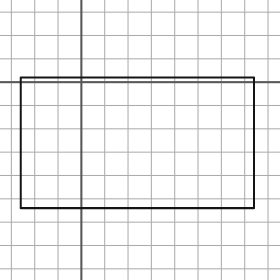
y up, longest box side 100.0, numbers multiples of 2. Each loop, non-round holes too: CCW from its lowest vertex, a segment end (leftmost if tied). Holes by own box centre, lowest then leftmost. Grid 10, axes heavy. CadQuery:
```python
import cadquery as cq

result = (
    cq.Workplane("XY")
    .moveTo(-26.0, -54.0)
    .lineTo(74.0, -54.0)
    .lineTo(74.0, 2.0)
    .lineTo(-26.0, 2.0)
    .close()
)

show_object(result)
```